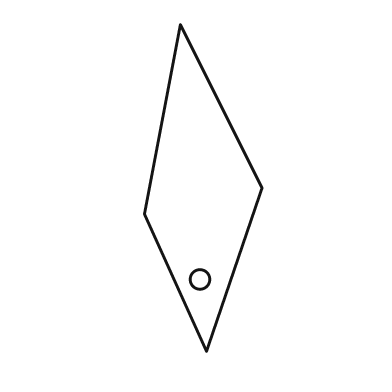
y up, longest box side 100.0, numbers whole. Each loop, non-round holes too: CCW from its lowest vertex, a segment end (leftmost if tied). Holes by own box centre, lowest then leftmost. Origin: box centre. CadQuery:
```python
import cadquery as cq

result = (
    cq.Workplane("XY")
    .moveTo(1.0, -50.0)
    .lineTo(18.0, 0.0)
    .lineTo(-7.0, 50.0)
    .lineTo(-18.0, -8.0)
    .close()
    .moveTo(-1.0, -28.0)
    .circle(3.0)
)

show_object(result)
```